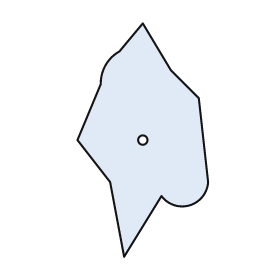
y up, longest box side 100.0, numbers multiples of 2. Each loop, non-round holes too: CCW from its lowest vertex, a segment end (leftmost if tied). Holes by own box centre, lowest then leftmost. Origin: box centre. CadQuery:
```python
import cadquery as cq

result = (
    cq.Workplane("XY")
    .moveTo(-8.0, -50.0)
    .lineTo(8.0, -24.0)
    .threePointArc((20.0, -28.0), (28.0, -18.0))
    .lineTo(24.0, 18.0)
    .lineTo(12.0, 30.0)
    .lineTo(0.0, 50.0)
    .lineTo(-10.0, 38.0)
    .threePointArc((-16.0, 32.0), (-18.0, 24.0))
    .lineTo(-28.0, 0.0)
    .lineTo(-14.0, -18.0)
    .close()
    .moveTo(0.0, 0.0)
    .circle(2.0)
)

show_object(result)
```